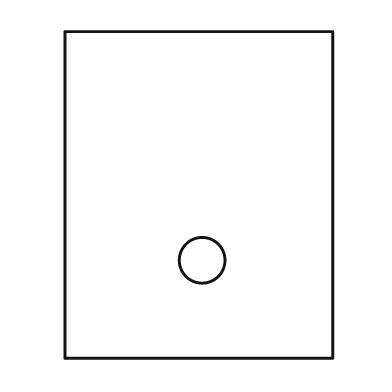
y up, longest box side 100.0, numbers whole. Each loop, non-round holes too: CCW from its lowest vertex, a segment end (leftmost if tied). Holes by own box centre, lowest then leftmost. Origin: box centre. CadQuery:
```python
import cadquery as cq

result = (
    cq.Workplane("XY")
    .moveTo(-41.0, -50.0)
    .lineTo(41.0, -50.0)
    .lineTo(41.0, 50.0)
    .lineTo(-41.0, 50.0)
    .close()
    .moveTo(1.0, -20.0)
    .circle(7.0)
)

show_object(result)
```